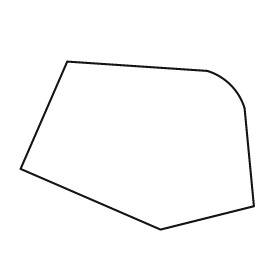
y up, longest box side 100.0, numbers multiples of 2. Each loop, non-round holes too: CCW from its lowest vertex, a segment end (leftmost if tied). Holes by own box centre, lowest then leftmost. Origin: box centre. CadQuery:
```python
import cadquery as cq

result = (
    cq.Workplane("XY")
    .moveTo(10.0, -36.0)
    .lineTo(50.0, -26.0)
    .lineTo(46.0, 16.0)
    .threePointArc((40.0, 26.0), (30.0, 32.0))
    .lineTo(-30.0, 36.0)
    .lineTo(-50.0, -10.0)
    .close()
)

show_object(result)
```